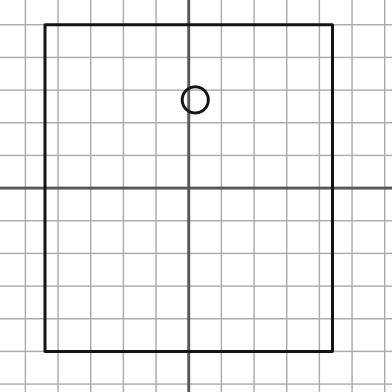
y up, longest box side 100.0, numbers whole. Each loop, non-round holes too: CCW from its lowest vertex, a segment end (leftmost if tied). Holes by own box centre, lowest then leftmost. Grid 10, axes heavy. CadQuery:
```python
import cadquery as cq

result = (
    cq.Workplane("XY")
    .moveTo(-44.0, -50.0)
    .lineTo(44.0, -50.0)
    .lineTo(44.0, 50.0)
    .lineTo(-44.0, 50.0)
    .close()
    .moveTo(2.0, 27.0)
    .circle(4.0)
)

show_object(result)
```